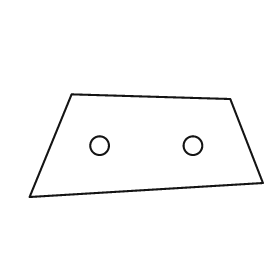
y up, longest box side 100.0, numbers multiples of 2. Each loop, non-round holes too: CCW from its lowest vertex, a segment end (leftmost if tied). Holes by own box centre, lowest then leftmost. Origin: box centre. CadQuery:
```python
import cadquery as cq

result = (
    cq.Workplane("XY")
    .moveTo(-50.0, -22.0)
    .lineTo(50.0, -16.0)
    .lineTo(36.0, 20.0)
    .lineTo(-32.0, 22.0)
    .close()
    .moveTo(-20.0, 0.0)
    .circle(4.0)
    .moveTo(20.0, 0.0)
    .circle(4.0)
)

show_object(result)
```